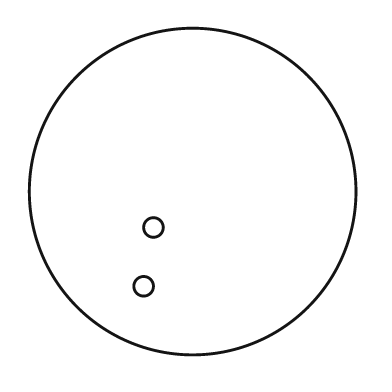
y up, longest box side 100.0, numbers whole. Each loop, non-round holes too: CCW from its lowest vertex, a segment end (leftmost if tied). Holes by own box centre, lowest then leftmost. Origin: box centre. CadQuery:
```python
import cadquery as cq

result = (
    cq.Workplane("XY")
    .moveTo(0.0, 0.0)
    .circle(50.0)
    .moveTo(-15.0, -29.0)
    .circle(3.0)
    .moveTo(-12.0, -11.0)
    .circle(3.0)
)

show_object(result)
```